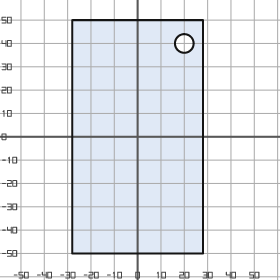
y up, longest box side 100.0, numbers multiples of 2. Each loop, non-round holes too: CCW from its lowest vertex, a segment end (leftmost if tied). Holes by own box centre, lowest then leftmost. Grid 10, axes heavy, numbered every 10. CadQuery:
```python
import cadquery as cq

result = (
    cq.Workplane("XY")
    .moveTo(-28.0, -50.0)
    .lineTo(28.0, -50.0)
    .lineTo(28.0, 50.0)
    .lineTo(-28.0, 50.0)
    .close()
    .moveTo(20.0, 40.0)
    .circle(4.0)
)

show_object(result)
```